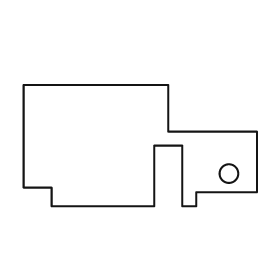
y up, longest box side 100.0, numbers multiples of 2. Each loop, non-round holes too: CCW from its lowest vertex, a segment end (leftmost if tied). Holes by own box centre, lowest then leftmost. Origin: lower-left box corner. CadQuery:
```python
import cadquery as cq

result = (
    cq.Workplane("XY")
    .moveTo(12.0, 0.0)
    .lineTo(56.0, 0.0)
    .lineTo(56.0, 26.0)
    .lineTo(68.0, 26.0)
    .lineTo(68.0, 0.0)
    .lineTo(74.0, 0.0)
    .lineTo(74.0, 6.0)
    .lineTo(100.0, 6.0)
    .lineTo(100.0, 32.0)
    .lineTo(62.0, 32.0)
    .lineTo(62.0, 52.0)
    .lineTo(0.0, 52.0)
    .lineTo(0.0, 8.0)
    .lineTo(12.0, 8.0)
    .close()
    .moveTo(88.0, 14.0)
    .circle(4.0)
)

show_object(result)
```